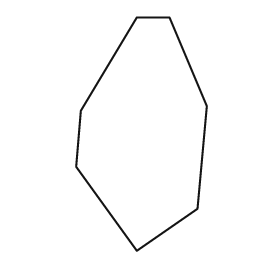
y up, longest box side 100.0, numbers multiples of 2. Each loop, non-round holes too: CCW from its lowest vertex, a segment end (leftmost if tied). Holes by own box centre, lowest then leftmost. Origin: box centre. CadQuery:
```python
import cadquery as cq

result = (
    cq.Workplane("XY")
    .moveTo(-2.0, -50.0)
    .lineTo(24.0, -32.0)
    .lineTo(28.0, 12.0)
    .lineTo(12.0, 50.0)
    .lineTo(-2.0, 50.0)
    .lineTo(-26.0, 10.0)
    .lineTo(-28.0, -14.0)
    .close()
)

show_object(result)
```